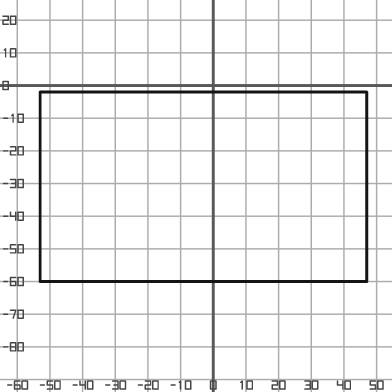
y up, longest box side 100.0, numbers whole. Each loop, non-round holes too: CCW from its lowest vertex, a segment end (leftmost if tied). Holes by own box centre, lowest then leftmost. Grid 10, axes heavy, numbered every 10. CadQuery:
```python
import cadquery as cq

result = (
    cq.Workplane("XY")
    .moveTo(-53.0, -60.0)
    .lineTo(47.0, -60.0)
    .lineTo(47.0, -2.0)
    .lineTo(-53.0, -2.0)
    .close()
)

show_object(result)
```